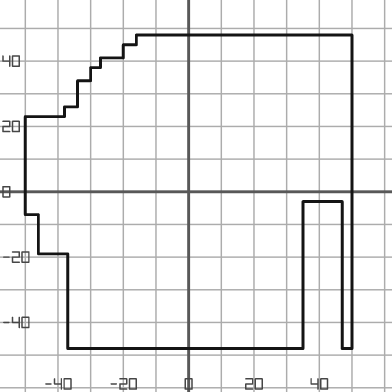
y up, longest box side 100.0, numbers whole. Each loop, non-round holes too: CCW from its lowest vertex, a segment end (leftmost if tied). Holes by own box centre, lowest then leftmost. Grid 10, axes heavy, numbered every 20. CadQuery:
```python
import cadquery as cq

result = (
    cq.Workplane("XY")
    .moveTo(-37.0, -48.0)
    .lineTo(35.0, -48.0)
    .lineTo(35.0, -3.0)
    .lineTo(47.0, -3.0)
    .lineTo(47.0, -48.0)
    .lineTo(50.0, -48.0)
    .lineTo(50.0, 48.0)
    .lineTo(-16.0, 48.0)
    .lineTo(-16.0, 45.0)
    .lineTo(-20.0, 45.0)
    .lineTo(-20.0, 41.0)
    .lineTo(-27.0, 41.0)
    .lineTo(-27.0, 38.0)
    .lineTo(-30.0, 38.0)
    .lineTo(-30.0, 34.0)
    .lineTo(-34.0, 34.0)
    .lineTo(-34.0, 26.0)
    .lineTo(-38.0, 26.0)
    .lineTo(-38.0, 23.0)
    .lineTo(-50.0, 23.0)
    .lineTo(-50.0, -7.0)
    .lineTo(-46.0, -7.0)
    .lineTo(-46.0, -19.0)
    .lineTo(-37.0, -19.0)
    .close()
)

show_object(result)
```